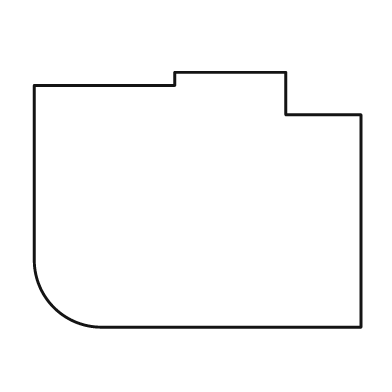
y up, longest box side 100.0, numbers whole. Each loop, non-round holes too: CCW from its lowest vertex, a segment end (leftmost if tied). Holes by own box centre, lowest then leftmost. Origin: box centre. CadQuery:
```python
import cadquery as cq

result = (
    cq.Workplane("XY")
    .moveTo(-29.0, -39.0)
    .lineTo(50.0, -39.0)
    .lineTo(50.0, 26.0)
    .lineTo(27.0, 26.0)
    .lineTo(27.0, 39.0)
    .lineTo(-7.0, 39.0)
    .lineTo(-7.0, 35.0)
    .lineTo(-50.0, 35.0)
    .lineTo(-50.0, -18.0)
    .threePointArc((-44.0, -33.0), (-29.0, -39.0))
    .close()
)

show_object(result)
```